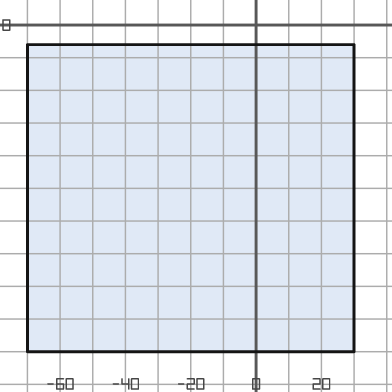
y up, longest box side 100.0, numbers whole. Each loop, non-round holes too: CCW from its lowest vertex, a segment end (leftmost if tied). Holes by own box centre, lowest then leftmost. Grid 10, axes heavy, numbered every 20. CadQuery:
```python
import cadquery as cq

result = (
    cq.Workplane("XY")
    .moveTo(-70.0, -100.0)
    .lineTo(30.0, -100.0)
    .lineTo(30.0, -6.0)
    .lineTo(-70.0, -6.0)
    .close()
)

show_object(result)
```